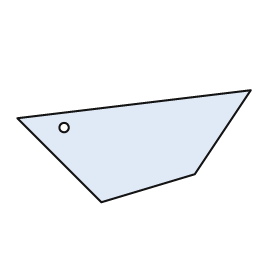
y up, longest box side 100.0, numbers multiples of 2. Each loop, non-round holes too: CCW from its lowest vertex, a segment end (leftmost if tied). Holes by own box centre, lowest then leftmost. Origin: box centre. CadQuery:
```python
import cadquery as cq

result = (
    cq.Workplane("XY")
    .moveTo(-14.0, -24.0)
    .lineTo(26.0, -12.0)
    .lineTo(50.0, 24.0)
    .lineTo(-50.0, 12.0)
    .close()
    .moveTo(-30.0, 8.0)
    .circle(2.0)
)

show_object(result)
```